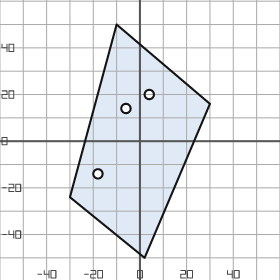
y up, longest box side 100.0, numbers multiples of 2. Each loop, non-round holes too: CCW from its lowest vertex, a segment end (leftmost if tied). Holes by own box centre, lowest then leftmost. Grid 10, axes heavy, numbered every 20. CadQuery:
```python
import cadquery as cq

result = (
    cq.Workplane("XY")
    .moveTo(2.0, -50.0)
    .lineTo(30.0, 16.0)
    .lineTo(-10.0, 50.0)
    .lineTo(-30.0, -24.0)
    .close()
    .moveTo(-18.0, -14.0)
    .circle(2.0)
    .moveTo(-6.0, 14.0)
    .circle(2.0)
    .moveTo(4.0, 20.0)
    .circle(2.0)
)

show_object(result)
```